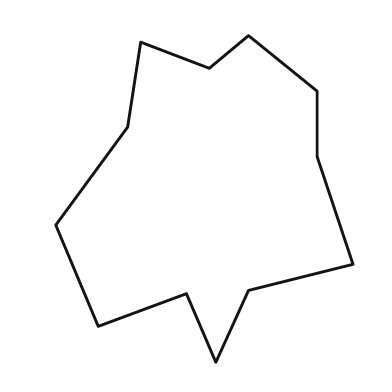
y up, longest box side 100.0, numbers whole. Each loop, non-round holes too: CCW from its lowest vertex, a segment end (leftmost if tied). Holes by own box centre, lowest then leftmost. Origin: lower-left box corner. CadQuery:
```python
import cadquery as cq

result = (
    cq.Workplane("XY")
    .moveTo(49.0, 0.0)
    .lineTo(59.0, 22.0)
    .lineTo(91.0, 30.0)
    .lineTo(80.0, 63.0)
    .lineTo(80.0, 83.0)
    .lineTo(59.0, 100.0)
    .lineTo(47.0, 90.0)
    .lineTo(26.0, 98.0)
    .lineTo(22.0, 72.0)
    .lineTo(0.0, 42.0)
    .lineTo(13.0, 11.0)
    .lineTo(40.0, 21.0)
    .close()
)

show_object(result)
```